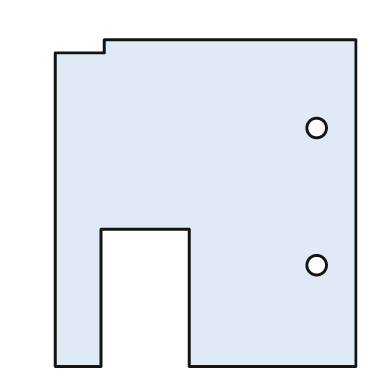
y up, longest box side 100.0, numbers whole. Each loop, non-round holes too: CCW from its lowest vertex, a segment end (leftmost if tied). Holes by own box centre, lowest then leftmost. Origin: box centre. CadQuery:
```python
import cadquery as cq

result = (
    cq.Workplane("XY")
    .moveTo(-46.0, -50.0)
    .lineTo(-32.0, -50.0)
    .lineTo(-32.0, -8.0)
    .lineTo(-5.0, -8.0)
    .lineTo(-5.0, -50.0)
    .lineTo(46.0, -50.0)
    .lineTo(46.0, 50.0)
    .lineTo(-31.0, 50.0)
    .lineTo(-31.0, 46.0)
    .lineTo(-46.0, 46.0)
    .close()
    .moveTo(34.0, -19.0)
    .circle(3.0)
    .moveTo(34.0, 23.0)
    .circle(3.0)
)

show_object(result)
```